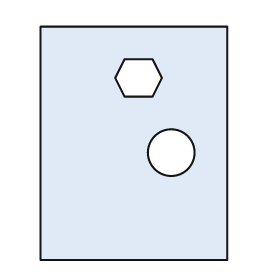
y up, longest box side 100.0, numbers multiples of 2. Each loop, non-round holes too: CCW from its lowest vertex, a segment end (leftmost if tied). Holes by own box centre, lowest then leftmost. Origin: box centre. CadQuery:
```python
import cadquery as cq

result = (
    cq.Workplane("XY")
    .moveTo(-40.0, -50.0)
    .lineTo(40.0, -50.0)
    .lineTo(40.0, 50.0)
    .lineTo(-40.0, 50.0)
    .close()
    .moveTo(16.0, -4.0)
    .circle(10.0)
    .moveTo(-4.0, 20.0)
    .lineTo(8.0, 20.0)
    .lineTo(12.0, 28.0)
    .lineTo(8.0, 36.0)
    .lineTo(-4.0, 36.0)
    .lineTo(-8.0, 28.0)
    .close()
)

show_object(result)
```